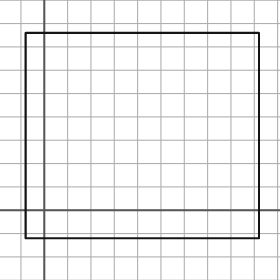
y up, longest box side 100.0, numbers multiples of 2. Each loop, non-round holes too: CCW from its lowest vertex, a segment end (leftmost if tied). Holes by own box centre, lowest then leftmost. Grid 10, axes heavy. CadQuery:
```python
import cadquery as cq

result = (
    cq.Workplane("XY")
    .moveTo(-8.0, -12.0)
    .lineTo(92.0, -12.0)
    .lineTo(92.0, 76.0)
    .lineTo(-8.0, 76.0)
    .close()
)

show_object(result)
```